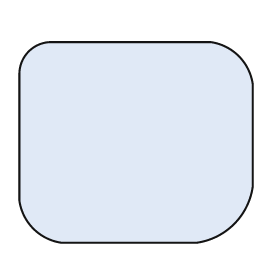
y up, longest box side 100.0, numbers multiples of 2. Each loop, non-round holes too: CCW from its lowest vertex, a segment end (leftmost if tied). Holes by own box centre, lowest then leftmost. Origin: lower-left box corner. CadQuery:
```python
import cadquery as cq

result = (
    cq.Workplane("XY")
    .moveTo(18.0, 0.0)
    .lineTo(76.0, 0.0)
    .threePointArc((92.0, 8.0), (100.0, 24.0))
    .lineTo(100.0, 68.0)
    .threePointArc((94.0, 80.0), (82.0, 86.0))
    .lineTo(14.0, 86.0)
    .threePointArc((4.0, 82.0), (0.0, 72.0))
    .lineTo(0.0, 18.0)
    .threePointArc((6.0, 6.0), (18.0, 0.0))
    .close()
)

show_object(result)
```